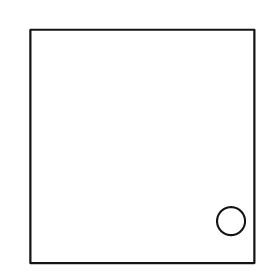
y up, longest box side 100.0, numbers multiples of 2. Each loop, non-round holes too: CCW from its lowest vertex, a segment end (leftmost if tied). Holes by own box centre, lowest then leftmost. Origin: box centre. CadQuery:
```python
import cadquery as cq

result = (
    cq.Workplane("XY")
    .moveTo(-48.0, -50.0)
    .lineTo(48.0, -50.0)
    .lineTo(48.0, 50.0)
    .lineTo(-48.0, 50.0)
    .close()
    .moveTo(38.0, -32.0)
    .circle(6.0)
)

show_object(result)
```